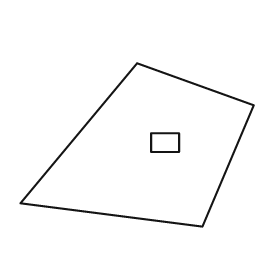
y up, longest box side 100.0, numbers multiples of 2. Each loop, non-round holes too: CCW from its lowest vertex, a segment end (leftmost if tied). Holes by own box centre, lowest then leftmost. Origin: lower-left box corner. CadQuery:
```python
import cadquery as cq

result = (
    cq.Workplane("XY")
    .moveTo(78.0, 0.0)
    .lineTo(100.0, 52.0)
    .lineTo(50.0, 70.0)
    .lineTo(0.0, 10.0)
    .close()
    .moveTo(56.0, 32.0)
    .lineTo(68.0, 32.0)
    .lineTo(68.0, 40.0)
    .lineTo(56.0, 40.0)
    .close()
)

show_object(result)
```